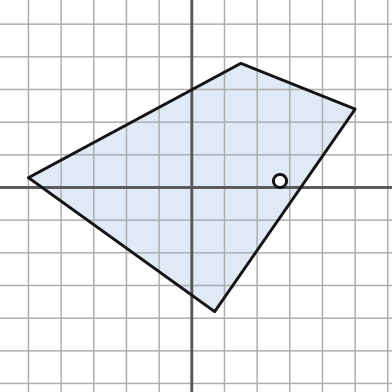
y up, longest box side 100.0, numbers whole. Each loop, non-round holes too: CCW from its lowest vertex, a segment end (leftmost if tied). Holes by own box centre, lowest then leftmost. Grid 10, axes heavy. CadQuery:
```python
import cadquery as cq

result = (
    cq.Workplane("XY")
    .moveTo(7.0, -38.0)
    .lineTo(50.0, 24.0)
    .lineTo(15.0, 38.0)
    .lineTo(-50.0, 3.0)
    .close()
    .moveTo(27.0, 2.0)
    .circle(2.0)
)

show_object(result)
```